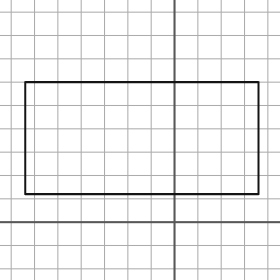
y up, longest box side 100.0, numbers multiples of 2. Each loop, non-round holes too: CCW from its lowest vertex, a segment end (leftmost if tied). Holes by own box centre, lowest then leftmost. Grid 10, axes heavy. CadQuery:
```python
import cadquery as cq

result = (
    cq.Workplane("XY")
    .moveTo(-64.0, 12.0)
    .lineTo(36.0, 12.0)
    .lineTo(36.0, 60.0)
    .lineTo(-64.0, 60.0)
    .close()
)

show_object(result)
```